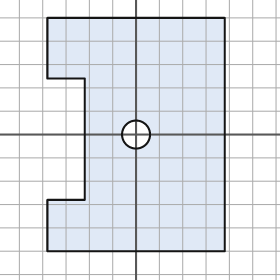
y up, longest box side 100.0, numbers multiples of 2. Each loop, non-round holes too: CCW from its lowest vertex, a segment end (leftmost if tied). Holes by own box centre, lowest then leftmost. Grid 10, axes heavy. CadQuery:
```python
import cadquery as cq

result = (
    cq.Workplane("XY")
    .moveTo(-38.0, -50.0)
    .lineTo(38.0, -50.0)
    .lineTo(38.0, 50.0)
    .lineTo(-38.0, 50.0)
    .lineTo(-38.0, 24.0)
    .lineTo(-22.0, 24.0)
    .lineTo(-22.0, -28.0)
    .lineTo(-38.0, -28.0)
    .close()
    .moveTo(0.0, 0.0)
    .circle(6.0)
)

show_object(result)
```